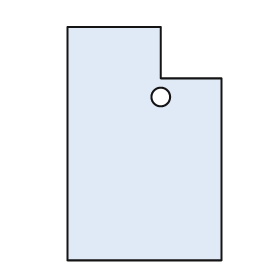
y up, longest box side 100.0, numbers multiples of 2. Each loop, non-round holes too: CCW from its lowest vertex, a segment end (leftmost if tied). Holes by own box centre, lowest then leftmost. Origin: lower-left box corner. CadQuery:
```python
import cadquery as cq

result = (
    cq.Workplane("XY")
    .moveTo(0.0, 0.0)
    .lineTo(66.0, 0.0)
    .lineTo(66.0, 78.0)
    .lineTo(40.0, 78.0)
    .lineTo(40.0, 100.0)
    .lineTo(0.0, 100.0)
    .close()
    .moveTo(40.0, 70.0)
    .circle(4.0)
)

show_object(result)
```